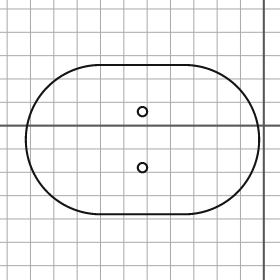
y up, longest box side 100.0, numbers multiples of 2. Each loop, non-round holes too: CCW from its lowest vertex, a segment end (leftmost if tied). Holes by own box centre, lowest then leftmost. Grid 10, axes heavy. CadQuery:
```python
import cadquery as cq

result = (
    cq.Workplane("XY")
    .moveTo(-70.0, -38.0)
    .lineTo(-34.0, -38.0)
    .threePointArc((-2.0, -6.0), (-34.0, 26.0))
    .lineTo(-70.0, 26.0)
    .threePointArc((-102.0, -6.0), (-70.0, -38.0))
    .close()
    .moveTo(-52.0, -18.0)
    .circle(2.0)
    .moveTo(-52.0, 6.0)
    .circle(2.0)
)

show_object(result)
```